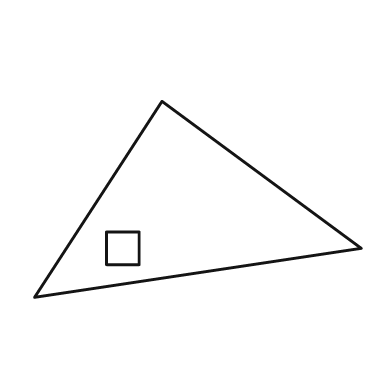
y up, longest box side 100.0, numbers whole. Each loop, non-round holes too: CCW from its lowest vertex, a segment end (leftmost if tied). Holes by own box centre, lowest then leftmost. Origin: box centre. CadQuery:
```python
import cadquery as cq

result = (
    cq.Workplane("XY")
    .moveTo(-50.0, -30.0)
    .lineTo(50.0, -15.0)
    .lineTo(-11.0, 30.0)
    .close()
    .moveTo(-28.0, -20.0)
    .lineTo(-18.0, -20.0)
    .lineTo(-18.0, -10.0)
    .lineTo(-28.0, -10.0)
    .close()
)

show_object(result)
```